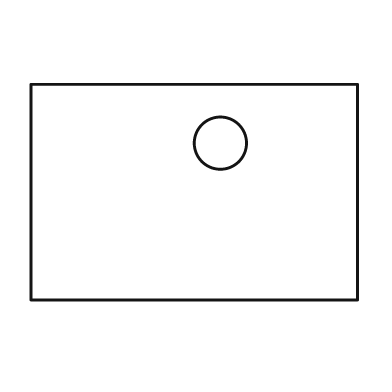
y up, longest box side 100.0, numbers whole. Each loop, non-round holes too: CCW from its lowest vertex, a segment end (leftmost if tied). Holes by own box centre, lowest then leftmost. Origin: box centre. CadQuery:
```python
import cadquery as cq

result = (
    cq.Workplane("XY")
    .moveTo(-50.0, -33.0)
    .lineTo(50.0, -33.0)
    .lineTo(50.0, 33.0)
    .lineTo(-50.0, 33.0)
    .close()
    .moveTo(8.0, 15.0)
    .circle(8.0)
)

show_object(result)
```